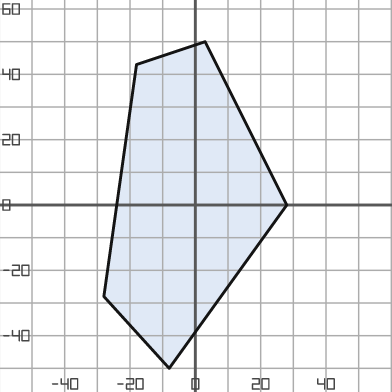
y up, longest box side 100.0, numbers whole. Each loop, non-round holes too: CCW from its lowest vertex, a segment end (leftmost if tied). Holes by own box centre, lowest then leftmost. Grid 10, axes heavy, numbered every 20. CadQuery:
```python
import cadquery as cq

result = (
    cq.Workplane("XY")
    .moveTo(-8.0, -50.0)
    .lineTo(28.0, 0.0)
    .lineTo(3.0, 50.0)
    .lineTo(-18.0, 43.0)
    .lineTo(-28.0, -28.0)
    .close()
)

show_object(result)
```